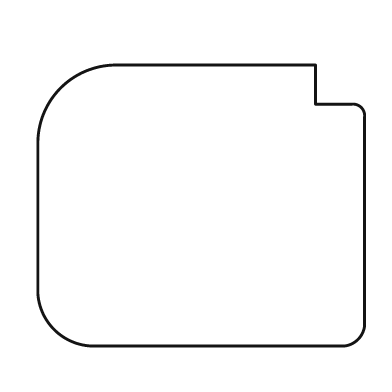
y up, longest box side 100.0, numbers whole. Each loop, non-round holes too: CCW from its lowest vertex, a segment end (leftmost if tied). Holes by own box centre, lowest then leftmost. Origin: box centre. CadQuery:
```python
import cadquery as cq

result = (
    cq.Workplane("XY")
    .moveTo(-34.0, -43.0)
    .lineTo(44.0, -43.0)
    .threePointArc((48.0, -41.0), (50.0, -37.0))
    .lineTo(50.0, 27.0)
    .threePointArc((49.0, 30.0), (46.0, 31.0))
    .lineTo(35.0, 31.0)
    .lineTo(35.0, 43.0)
    .lineTo(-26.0, 43.0)
    .threePointArc((-43.0, 36.0), (-50.0, 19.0))
    .lineTo(-50.0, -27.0)
    .threePointArc((-45.0, -38.0), (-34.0, -43.0))
    .close()
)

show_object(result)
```